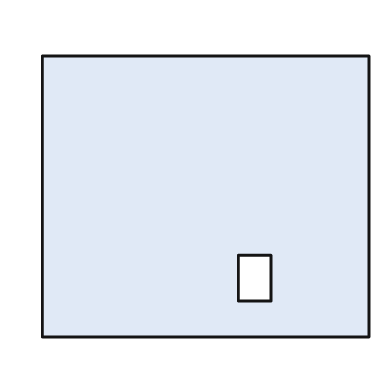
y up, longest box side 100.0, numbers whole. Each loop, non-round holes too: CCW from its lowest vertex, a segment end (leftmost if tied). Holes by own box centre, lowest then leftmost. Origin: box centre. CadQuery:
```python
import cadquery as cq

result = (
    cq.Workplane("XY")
    .moveTo(-50.0, -43.0)
    .lineTo(50.0, -43.0)
    .lineTo(50.0, 43.0)
    .lineTo(-50.0, 43.0)
    .close()
    .moveTo(10.0, -32.0)
    .lineTo(20.0, -32.0)
    .lineTo(20.0, -18.0)
    .lineTo(10.0, -18.0)
    .close()
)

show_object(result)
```